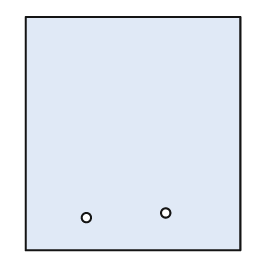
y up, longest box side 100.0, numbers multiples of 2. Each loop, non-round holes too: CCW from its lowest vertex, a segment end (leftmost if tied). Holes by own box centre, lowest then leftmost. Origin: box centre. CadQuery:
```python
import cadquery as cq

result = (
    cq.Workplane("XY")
    .moveTo(-46.0, -50.0)
    .lineTo(46.0, -50.0)
    .lineTo(46.0, 50.0)
    .lineTo(-46.0, 50.0)
    .close()
    .moveTo(-20.0, -36.0)
    .circle(2.0)
    .moveTo(14.0, -34.0)
    .circle(2.0)
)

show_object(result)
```